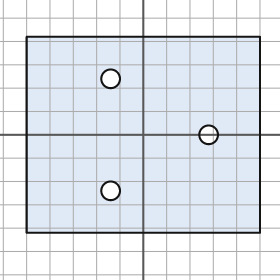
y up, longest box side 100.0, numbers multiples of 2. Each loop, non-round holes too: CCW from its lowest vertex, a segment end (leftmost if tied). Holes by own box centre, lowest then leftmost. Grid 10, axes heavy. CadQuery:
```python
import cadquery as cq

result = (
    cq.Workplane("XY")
    .moveTo(-50.0, -42.0)
    .lineTo(50.0, -42.0)
    .lineTo(50.0, 42.0)
    .lineTo(-50.0, 42.0)
    .close()
    .moveTo(-14.0, -24.0)
    .circle(4.0)
    .moveTo(28.0, 0.0)
    .circle(4.0)
    .moveTo(-14.0, 24.0)
    .circle(4.0)
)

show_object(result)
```